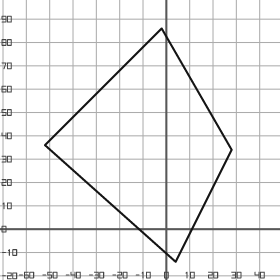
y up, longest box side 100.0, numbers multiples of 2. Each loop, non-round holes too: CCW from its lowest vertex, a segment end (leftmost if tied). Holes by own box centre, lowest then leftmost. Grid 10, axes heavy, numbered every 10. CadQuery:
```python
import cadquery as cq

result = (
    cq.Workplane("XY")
    .moveTo(4.0, -14.0)
    .lineTo(28.0, 34.0)
    .lineTo(-2.0, 86.0)
    .lineTo(-52.0, 36.0)
    .close()
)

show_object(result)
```